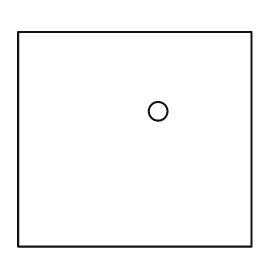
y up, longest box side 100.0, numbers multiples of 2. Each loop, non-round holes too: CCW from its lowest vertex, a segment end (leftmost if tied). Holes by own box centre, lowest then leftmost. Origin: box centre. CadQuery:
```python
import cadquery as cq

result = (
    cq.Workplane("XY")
    .moveTo(-50.0, -46.0)
    .lineTo(50.0, -46.0)
    .lineTo(50.0, 46.0)
    .lineTo(-50.0, 46.0)
    .close()
    .moveTo(10.0, 12.0)
    .circle(4.0)
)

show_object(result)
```